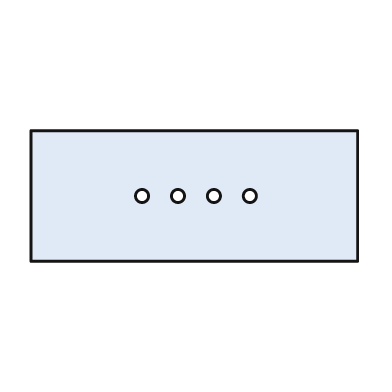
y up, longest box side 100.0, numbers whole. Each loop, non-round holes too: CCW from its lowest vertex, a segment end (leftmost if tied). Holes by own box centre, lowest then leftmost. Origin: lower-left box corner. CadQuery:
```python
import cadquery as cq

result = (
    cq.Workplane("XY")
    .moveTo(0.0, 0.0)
    .lineTo(100.0, 0.0)
    .lineTo(100.0, 40.0)
    .lineTo(0.0, 40.0)
    .close()
    .moveTo(34.0, 20.0)
    .circle(2.0)
    .moveTo(45.0, 20.0)
    .circle(2.0)
    .moveTo(56.0, 20.0)
    .circle(2.0)
    .moveTo(67.0, 20.0)
    .circle(2.0)
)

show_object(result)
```